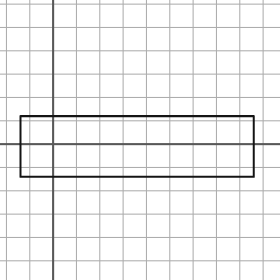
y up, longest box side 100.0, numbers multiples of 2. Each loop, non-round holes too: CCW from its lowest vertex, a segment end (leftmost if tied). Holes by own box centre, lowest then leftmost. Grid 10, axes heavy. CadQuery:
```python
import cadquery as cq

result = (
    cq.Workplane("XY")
    .moveTo(-14.0, -14.0)
    .lineTo(86.0, -14.0)
    .lineTo(86.0, 12.0)
    .lineTo(-14.0, 12.0)
    .close()
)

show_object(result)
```